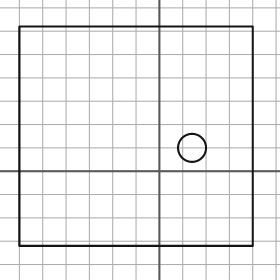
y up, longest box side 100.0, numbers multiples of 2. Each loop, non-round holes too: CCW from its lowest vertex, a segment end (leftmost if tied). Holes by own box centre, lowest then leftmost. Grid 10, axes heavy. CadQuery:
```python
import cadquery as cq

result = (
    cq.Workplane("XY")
    .moveTo(-60.0, -32.0)
    .lineTo(40.0, -32.0)
    .lineTo(40.0, 62.0)
    .lineTo(-60.0, 62.0)
    .close()
    .moveTo(14.0, 10.0)
    .circle(6.0)
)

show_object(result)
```